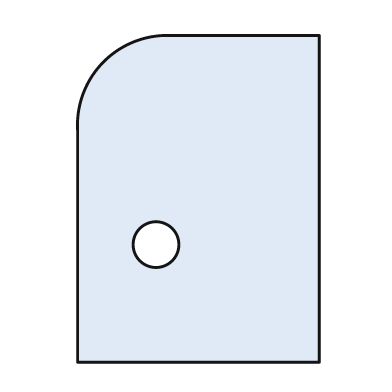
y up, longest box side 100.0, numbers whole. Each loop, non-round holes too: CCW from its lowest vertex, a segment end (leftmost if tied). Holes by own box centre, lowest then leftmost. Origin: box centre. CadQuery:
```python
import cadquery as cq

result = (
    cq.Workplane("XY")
    .moveTo(-37.0, -50.0)
    .lineTo(37.0, -50.0)
    .lineTo(37.0, 50.0)
    .lineTo(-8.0, 50.0)
    .threePointArc((-29.0, 42.0), (-37.0, 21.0))
    .close()
    .moveTo(-13.0, -14.0)
    .circle(7.0)
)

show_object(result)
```